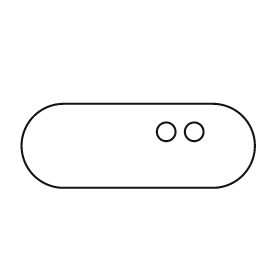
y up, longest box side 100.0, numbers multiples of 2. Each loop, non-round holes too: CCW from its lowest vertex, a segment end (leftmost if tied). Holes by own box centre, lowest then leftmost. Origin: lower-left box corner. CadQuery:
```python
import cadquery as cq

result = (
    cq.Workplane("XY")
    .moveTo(18.0, 0.0)
    .lineTo(82.0, 0.0)
    .threePointArc((100.0, 18.0), (82.0, 36.0))
    .lineTo(18.0, 36.0)
    .threePointArc((0.0, 18.0), (18.0, 0.0))
    .close()
    .moveTo(62.0, 24.0)
    .circle(4.0)
    .moveTo(74.0, 24.0)
    .circle(4.0)
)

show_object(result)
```